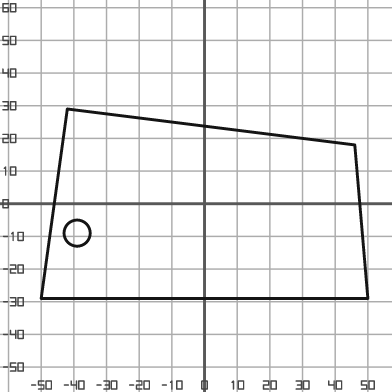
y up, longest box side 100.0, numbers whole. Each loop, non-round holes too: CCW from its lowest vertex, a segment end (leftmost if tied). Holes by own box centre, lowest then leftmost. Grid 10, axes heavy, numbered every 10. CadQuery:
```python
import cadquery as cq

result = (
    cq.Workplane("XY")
    .moveTo(-50.0, -29.0)
    .lineTo(50.0, -29.0)
    .lineTo(46.0, 18.0)
    .lineTo(-42.0, 29.0)
    .close()
    .moveTo(-39.0, -9.0)
    .circle(4.0)
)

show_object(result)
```